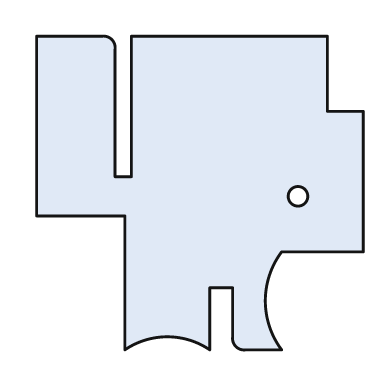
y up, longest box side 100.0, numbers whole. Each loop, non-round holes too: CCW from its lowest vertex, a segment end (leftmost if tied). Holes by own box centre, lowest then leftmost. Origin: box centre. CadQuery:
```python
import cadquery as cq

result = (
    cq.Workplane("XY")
    .moveTo(-23.0, -48.0)
    .threePointArc((-10.0, -44.0), (3.0, -48.0))
    .lineTo(3.0, -29.0)
    .lineTo(10.0, -29.0)
    .lineTo(10.0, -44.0)
    .threePointArc((11.0, -47.0), (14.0, -48.0))
    .lineTo(25.0, -48.0)
    .threePointArc((20.0, -33.0), (25.0, -18.0))
    .lineTo(50.0, -18.0)
    .lineTo(50.0, 25.0)
    .lineTo(39.0, 25.0)
    .lineTo(39.0, 48.0)
    .lineTo(-21.0, 48.0)
    .lineTo(-21.0, 5.0)
    .lineTo(-26.0, 5.0)
    .lineTo(-26.0, 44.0)
    .threePointArc((-27.0, 47.0), (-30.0, 48.0))
    .lineTo(-50.0, 48.0)
    .lineTo(-50.0, -7.0)
    .lineTo(-23.0, -7.0)
    .close()
    .moveTo(30.0, -1.0)
    .circle(3.0)
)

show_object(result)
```